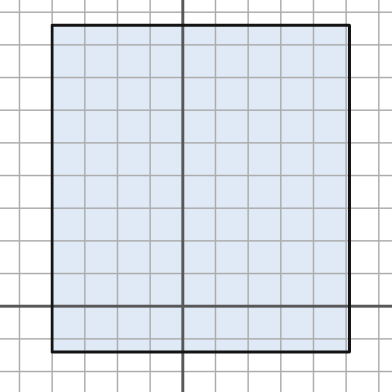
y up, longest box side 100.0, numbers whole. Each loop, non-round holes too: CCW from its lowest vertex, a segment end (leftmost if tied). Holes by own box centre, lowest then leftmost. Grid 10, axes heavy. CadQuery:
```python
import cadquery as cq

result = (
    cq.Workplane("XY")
    .moveTo(-40.0, -14.0)
    .lineTo(51.0, -14.0)
    .lineTo(51.0, 86.0)
    .lineTo(-40.0, 86.0)
    .close()
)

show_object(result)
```